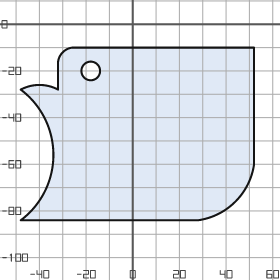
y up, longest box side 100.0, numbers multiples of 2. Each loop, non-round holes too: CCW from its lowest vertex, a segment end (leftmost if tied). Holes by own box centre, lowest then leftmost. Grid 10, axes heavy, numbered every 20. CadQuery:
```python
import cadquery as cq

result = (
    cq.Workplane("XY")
    .moveTo(-48.0, -84.0)
    .lineTo(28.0, -84.0)
    .threePointArc((44.0, -76.0), (52.0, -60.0))
    .lineTo(52.0, -10.0)
    .lineTo(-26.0, -10.0)
    .threePointArc((-30.0, -12.0), (-32.0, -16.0))
    .lineTo(-32.0, -28.0)
    .threePointArc((-40.0, -26.0), (-48.0, -28.0))
    .threePointArc((-34.0, -56.0), (-48.0, -84.0))
    .close()
    .moveTo(-18.0, -20.0)
    .circle(4.0)
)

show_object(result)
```